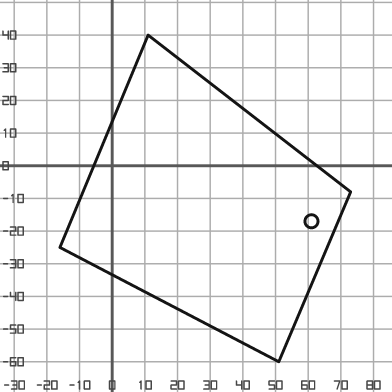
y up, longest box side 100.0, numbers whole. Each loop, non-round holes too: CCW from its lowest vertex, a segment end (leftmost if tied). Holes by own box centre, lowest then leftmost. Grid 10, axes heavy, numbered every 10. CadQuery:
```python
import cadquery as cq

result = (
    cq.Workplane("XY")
    .moveTo(51.0, -60.0)
    .lineTo(73.0, -8.0)
    .lineTo(11.0, 40.0)
    .lineTo(-16.0, -25.0)
    .close()
    .moveTo(61.0, -17.0)
    .circle(2.0)
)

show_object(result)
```